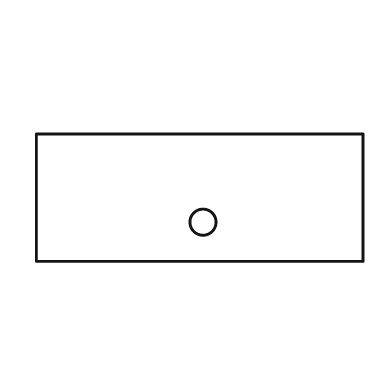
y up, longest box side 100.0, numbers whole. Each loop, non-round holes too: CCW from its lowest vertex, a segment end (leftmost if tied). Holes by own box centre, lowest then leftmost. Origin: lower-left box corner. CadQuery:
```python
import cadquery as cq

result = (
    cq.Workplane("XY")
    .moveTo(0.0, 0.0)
    .lineTo(100.0, 0.0)
    .lineTo(100.0, 39.0)
    .lineTo(0.0, 39.0)
    .close()
    .moveTo(51.0, 12.0)
    .circle(4.0)
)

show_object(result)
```